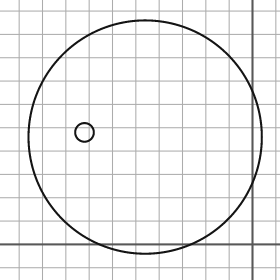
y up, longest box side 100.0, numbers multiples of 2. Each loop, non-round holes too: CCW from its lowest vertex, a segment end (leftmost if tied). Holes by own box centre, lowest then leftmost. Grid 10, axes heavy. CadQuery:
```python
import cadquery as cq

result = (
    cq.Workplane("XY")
    .moveTo(-46.0, 46.0)
    .circle(50.0)
    .moveTo(-72.0, 48.0)
    .circle(4.0)
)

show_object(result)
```